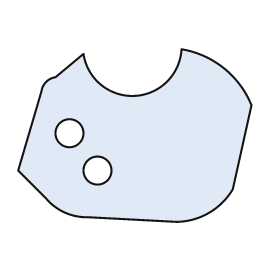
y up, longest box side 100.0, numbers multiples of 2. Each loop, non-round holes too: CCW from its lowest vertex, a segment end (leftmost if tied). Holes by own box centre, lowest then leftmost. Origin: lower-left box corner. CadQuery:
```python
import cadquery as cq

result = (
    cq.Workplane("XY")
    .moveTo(68.0, 0.0)
    .threePointArc((82.0, 4.0), (92.0, 14.0))
    .lineTo(100.0, 50.0)
    .threePointArc((88.0, 66.0), (70.0, 74.0))
    .threePointArc((50.0, 54.0), (28.0, 72.0))
    .lineTo(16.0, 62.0)
    .threePointArc((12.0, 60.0), (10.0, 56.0))
    .lineTo(0.0, 22.0)
    .lineTo(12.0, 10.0)
    .threePointArc((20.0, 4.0), (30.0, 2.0))
    .close()
    .moveTo(34.0, 22.0)
    .circle(6.0)
    .moveTo(22.0, 38.0)
    .circle(6.0)
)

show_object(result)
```